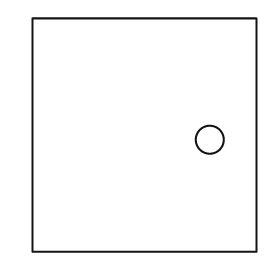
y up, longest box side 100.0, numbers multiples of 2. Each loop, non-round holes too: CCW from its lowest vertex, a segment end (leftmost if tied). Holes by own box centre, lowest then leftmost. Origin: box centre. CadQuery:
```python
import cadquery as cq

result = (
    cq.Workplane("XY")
    .moveTo(-48.0, -50.0)
    .lineTo(48.0, -50.0)
    .lineTo(48.0, 50.0)
    .lineTo(-48.0, 50.0)
    .close()
    .moveTo(28.0, -2.0)
    .circle(6.0)
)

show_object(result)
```